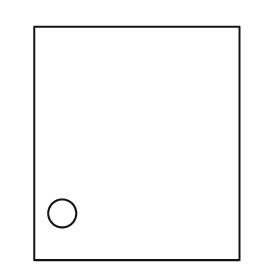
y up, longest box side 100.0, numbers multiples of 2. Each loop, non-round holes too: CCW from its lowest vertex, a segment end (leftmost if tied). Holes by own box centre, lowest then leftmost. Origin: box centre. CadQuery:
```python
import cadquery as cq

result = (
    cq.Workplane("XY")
    .moveTo(-44.0, -50.0)
    .lineTo(44.0, -50.0)
    .lineTo(44.0, 50.0)
    .lineTo(-44.0, 50.0)
    .close()
    .moveTo(-32.0, -30.0)
    .circle(6.0)
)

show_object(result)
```